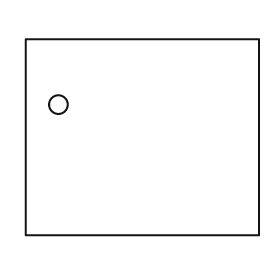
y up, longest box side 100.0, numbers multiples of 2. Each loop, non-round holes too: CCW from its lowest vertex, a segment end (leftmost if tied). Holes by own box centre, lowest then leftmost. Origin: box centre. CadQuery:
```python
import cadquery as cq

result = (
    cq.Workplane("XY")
    .moveTo(-50.0, -42.0)
    .lineTo(50.0, -42.0)
    .lineTo(50.0, 42.0)
    .lineTo(-50.0, 42.0)
    .close()
    .moveTo(-36.0, 14.0)
    .circle(4.0)
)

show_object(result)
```